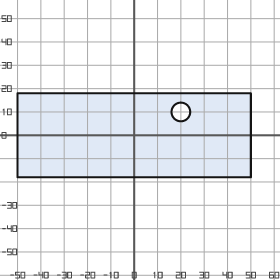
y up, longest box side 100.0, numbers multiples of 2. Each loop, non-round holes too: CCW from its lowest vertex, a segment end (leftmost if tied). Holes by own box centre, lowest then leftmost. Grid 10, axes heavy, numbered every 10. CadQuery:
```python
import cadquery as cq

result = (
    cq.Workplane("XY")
    .moveTo(-50.0, -18.0)
    .lineTo(50.0, -18.0)
    .lineTo(50.0, 18.0)
    .lineTo(-50.0, 18.0)
    .close()
    .moveTo(20.0, 10.0)
    .circle(4.0)
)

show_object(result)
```